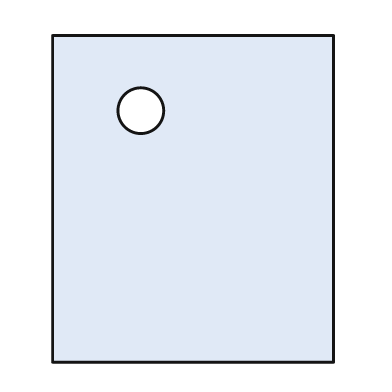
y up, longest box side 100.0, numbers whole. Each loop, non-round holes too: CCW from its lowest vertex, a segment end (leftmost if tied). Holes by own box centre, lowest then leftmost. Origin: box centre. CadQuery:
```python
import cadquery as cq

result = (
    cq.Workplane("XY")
    .moveTo(-43.0, -50.0)
    .lineTo(43.0, -50.0)
    .lineTo(43.0, 50.0)
    .lineTo(-43.0, 50.0)
    .close()
    .moveTo(-16.0, 27.0)
    .circle(7.0)
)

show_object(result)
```